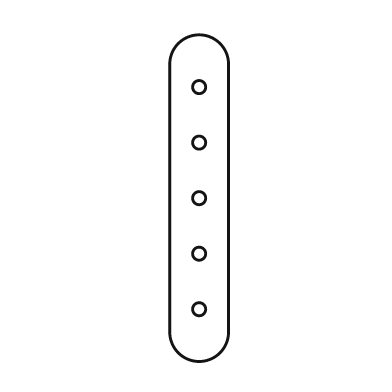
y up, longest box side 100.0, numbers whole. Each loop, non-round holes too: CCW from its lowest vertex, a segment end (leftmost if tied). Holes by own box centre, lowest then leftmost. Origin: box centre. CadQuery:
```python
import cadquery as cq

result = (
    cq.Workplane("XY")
    .moveTo(-9.0, -41.0)
    .threePointArc((0.0, -50.0), (9.0, -41.0))
    .lineTo(9.0, 41.0)
    .threePointArc((0.0, 50.0), (-9.0, 41.0))
    .close()
    .moveTo(0.0, -34.0)
    .circle(2.0)
    .moveTo(0.0, -17.0)
    .circle(2.0)
    .moveTo(0.0, 0.0)
    .circle(2.0)
    .moveTo(0.0, 17.0)
    .circle(2.0)
    .moveTo(0.0, 34.0)
    .circle(2.0)
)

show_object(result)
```